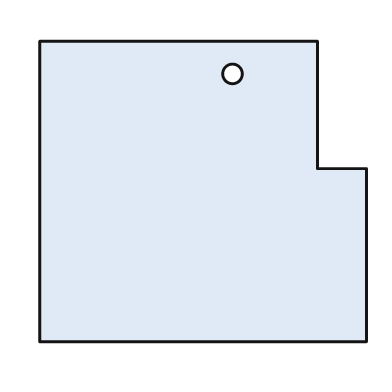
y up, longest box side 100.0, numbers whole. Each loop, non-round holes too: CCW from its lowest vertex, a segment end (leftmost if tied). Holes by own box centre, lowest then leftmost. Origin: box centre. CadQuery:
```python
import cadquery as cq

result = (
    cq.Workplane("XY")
    .moveTo(-50.0, -46.0)
    .lineTo(50.0, -46.0)
    .lineTo(50.0, 7.0)
    .lineTo(35.0, 7.0)
    .lineTo(35.0, 46.0)
    .lineTo(-50.0, 46.0)
    .close()
    .moveTo(9.0, 36.0)
    .circle(3.0)
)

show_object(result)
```